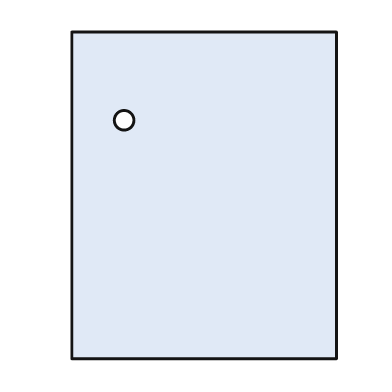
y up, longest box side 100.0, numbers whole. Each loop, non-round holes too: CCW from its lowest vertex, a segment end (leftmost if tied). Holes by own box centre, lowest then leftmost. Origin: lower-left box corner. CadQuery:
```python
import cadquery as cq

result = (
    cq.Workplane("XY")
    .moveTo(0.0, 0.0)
    .lineTo(81.0, 0.0)
    .lineTo(81.0, 100.0)
    .lineTo(0.0, 100.0)
    .close()
    .moveTo(16.0, 73.0)
    .circle(3.0)
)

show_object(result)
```